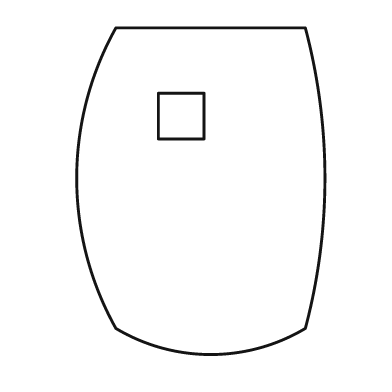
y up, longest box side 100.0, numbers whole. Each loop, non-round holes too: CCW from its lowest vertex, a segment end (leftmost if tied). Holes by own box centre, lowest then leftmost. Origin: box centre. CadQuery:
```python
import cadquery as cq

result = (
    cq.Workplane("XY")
    .moveTo(-26.0, -42.0)
    .threePointArc((3.0, -50.0), (32.0, -42.0))
    .threePointArc((38.0, 4.0), (32.0, 50.0))
    .lineTo(-26.0, 50.0)
    .threePointArc((-38.0, 4.0), (-26.0, -42.0))
    .close()
    .moveTo(-13.0, 16.0)
    .lineTo(1.0, 16.0)
    .lineTo(1.0, 30.0)
    .lineTo(-13.0, 30.0)
    .close()
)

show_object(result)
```